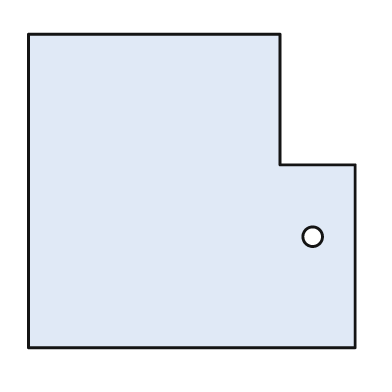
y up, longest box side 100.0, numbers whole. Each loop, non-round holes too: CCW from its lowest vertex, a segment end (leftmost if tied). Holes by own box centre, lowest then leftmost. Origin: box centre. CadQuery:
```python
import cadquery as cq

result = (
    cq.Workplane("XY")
    .moveTo(-50.0, -48.0)
    .lineTo(50.0, -48.0)
    .lineTo(50.0, 8.0)
    .lineTo(27.0, 8.0)
    .lineTo(27.0, 48.0)
    .lineTo(-50.0, 48.0)
    .close()
    .moveTo(37.0, -14.0)
    .circle(3.0)
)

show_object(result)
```